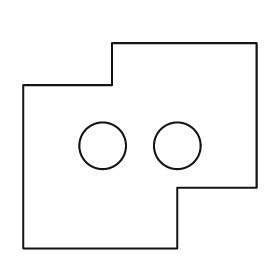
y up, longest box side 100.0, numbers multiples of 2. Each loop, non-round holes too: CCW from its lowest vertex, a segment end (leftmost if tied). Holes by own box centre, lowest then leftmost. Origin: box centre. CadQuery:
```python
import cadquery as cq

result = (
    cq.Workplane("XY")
    .moveTo(-50.0, -44.0)
    .lineTo(16.0, -44.0)
    .lineTo(16.0, -18.0)
    .lineTo(50.0, -18.0)
    .lineTo(50.0, 44.0)
    .lineTo(-12.0, 44.0)
    .lineTo(-12.0, 26.0)
    .lineTo(-50.0, 26.0)
    .close()
    .moveTo(-16.0, 0.0)
    .circle(10.0)
    .moveTo(16.0, 0.0)
    .circle(10.0)
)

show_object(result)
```